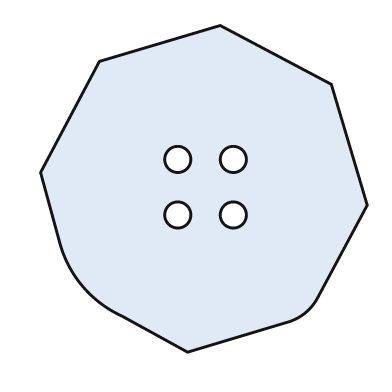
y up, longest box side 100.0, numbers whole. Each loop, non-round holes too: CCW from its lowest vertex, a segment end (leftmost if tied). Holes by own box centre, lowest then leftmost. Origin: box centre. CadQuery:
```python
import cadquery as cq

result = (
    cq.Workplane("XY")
    .moveTo(-5.0, -50.0)
    .lineTo(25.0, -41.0)
    .threePointArc((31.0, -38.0), (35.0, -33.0))
    .lineTo(50.0, -5.0)
    .lineTo(39.0, 32.0)
    .lineTo(5.0, 50.0)
    .lineTo(-32.0, 39.0)
    .lineTo(-50.0, 5.0)
    .lineTo(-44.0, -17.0)
    .threePointArc((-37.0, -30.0), (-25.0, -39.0))
    .close()
    .moveTo(-8.0, -8.0)
    .circle(4.0)
    .moveTo(9.0, -8.0)
    .circle(4.0)
    .moveTo(-8.0, 9.0)
    .circle(4.0)
    .moveTo(9.0, 9.0)
    .circle(4.0)
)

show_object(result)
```